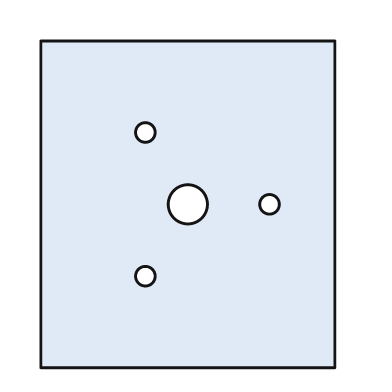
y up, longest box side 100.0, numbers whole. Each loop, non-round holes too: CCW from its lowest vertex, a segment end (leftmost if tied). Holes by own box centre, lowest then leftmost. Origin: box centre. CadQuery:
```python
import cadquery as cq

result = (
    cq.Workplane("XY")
    .moveTo(-45.0, -50.0)
    .lineTo(45.0, -50.0)
    .lineTo(45.0, 50.0)
    .lineTo(-45.0, 50.0)
    .close()
    .moveTo(-13.0, -22.0)
    .circle(3.0)
    .moveTo(0.0, 0.0)
    .circle(6.0)
    .moveTo(25.0, 0.0)
    .circle(3.0)
    .moveTo(-13.0, 22.0)
    .circle(3.0)
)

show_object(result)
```